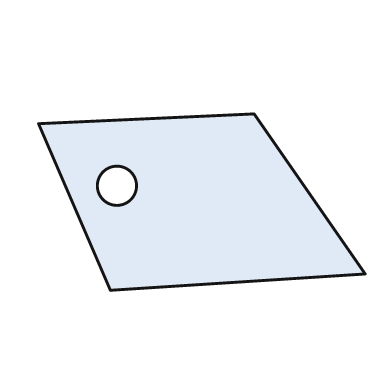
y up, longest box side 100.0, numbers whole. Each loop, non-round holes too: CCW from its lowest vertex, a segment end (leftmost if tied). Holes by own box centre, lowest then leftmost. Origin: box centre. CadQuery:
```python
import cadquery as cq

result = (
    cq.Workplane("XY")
    .moveTo(-28.0, -27.0)
    .lineTo(50.0, -22.0)
    .lineTo(16.0, 27.0)
    .lineTo(-50.0, 24.0)
    .close()
    .moveTo(-26.0, 5.0)
    .circle(6.0)
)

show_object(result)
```